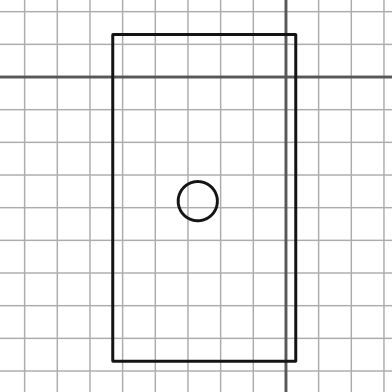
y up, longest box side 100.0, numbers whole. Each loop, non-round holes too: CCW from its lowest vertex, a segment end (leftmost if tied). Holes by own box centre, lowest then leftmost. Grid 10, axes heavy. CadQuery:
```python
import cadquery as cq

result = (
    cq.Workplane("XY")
    .moveTo(-53.0, -87.0)
    .lineTo(3.0, -87.0)
    .lineTo(3.0, 13.0)
    .lineTo(-53.0, 13.0)
    .close()
    .moveTo(-27.0, -38.0)
    .circle(6.0)
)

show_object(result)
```